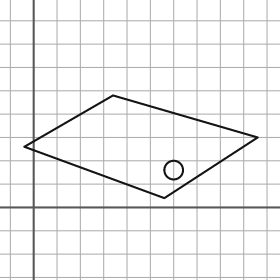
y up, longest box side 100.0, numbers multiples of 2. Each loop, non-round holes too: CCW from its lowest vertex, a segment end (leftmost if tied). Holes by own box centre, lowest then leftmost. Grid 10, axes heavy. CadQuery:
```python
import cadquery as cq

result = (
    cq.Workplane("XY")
    .moveTo(56.0, 4.0)
    .lineTo(96.0, 30.0)
    .lineTo(34.0, 48.0)
    .lineTo(-4.0, 26.0)
    .close()
    .moveTo(60.0, 16.0)
    .circle(4.0)
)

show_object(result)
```